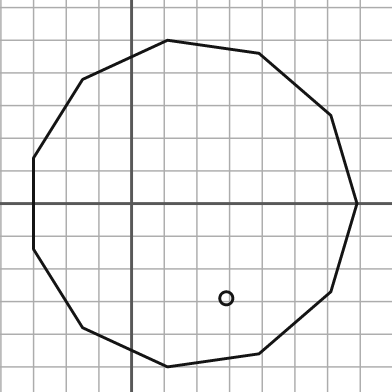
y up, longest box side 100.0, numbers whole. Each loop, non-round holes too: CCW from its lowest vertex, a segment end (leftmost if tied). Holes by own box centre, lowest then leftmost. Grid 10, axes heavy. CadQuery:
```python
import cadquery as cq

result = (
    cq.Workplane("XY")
    .moveTo(11.0, -50.0)
    .lineTo(39.0, -46.0)
    .lineTo(61.0, -27.0)
    .lineTo(69.0, 0.0)
    .lineTo(61.0, 27.0)
    .lineTo(39.0, 46.0)
    .lineTo(11.0, 50.0)
    .lineTo(-15.0, 38.0)
    .lineTo(-30.0, 14.0)
    .lineTo(-30.0, -14.0)
    .lineTo(-15.0, -38.0)
    .close()
    .moveTo(29.0, -29.0)
    .circle(2.0)
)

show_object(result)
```